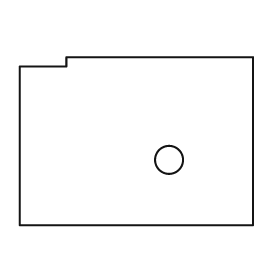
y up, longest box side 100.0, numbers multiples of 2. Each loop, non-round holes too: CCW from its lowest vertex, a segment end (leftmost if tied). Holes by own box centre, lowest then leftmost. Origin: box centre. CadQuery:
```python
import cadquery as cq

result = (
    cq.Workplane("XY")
    .moveTo(-50.0, -36.0)
    .lineTo(50.0, -36.0)
    .lineTo(50.0, 36.0)
    .lineTo(-30.0, 36.0)
    .lineTo(-30.0, 32.0)
    .lineTo(-50.0, 32.0)
    .close()
    .moveTo(14.0, -8.0)
    .circle(6.0)
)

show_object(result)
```